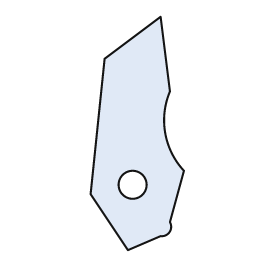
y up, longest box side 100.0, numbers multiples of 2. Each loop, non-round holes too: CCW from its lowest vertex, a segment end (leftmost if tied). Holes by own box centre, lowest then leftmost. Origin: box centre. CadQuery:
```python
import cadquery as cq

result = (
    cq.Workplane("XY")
    .moveTo(-4.0, -50.0)
    .lineTo(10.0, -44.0)
    .threePointArc((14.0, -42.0), (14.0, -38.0))
    .lineTo(20.0, -16.0)
    .threePointArc((12.0, 0.0), (14.0, 18.0))
    .lineTo(10.0, 50.0)
    .lineTo(-14.0, 32.0)
    .lineTo(-20.0, -26.0)
    .close()
    .moveTo(-2.0, -22.0)
    .circle(6.0)
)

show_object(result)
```